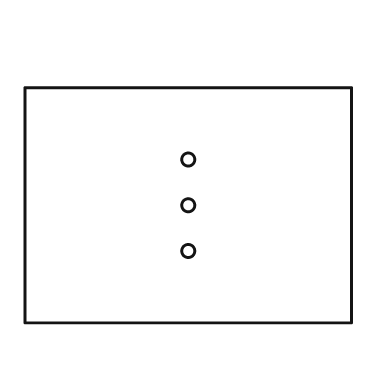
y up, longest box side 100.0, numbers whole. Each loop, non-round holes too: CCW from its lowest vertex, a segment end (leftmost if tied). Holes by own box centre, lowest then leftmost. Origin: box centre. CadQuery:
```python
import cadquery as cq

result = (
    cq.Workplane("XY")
    .moveTo(-50.0, -36.0)
    .lineTo(50.0, -36.0)
    .lineTo(50.0, 36.0)
    .lineTo(-50.0, 36.0)
    .close()
    .moveTo(0.0, -14.0)
    .circle(2.0)
    .moveTo(0.0, 0.0)
    .circle(2.0)
    .moveTo(0.0, 14.0)
    .circle(2.0)
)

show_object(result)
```